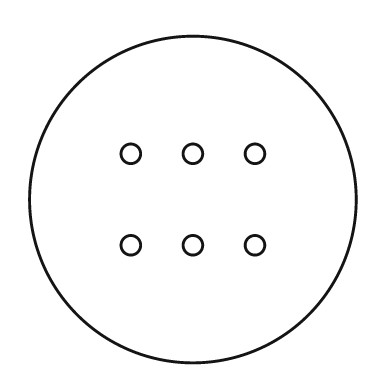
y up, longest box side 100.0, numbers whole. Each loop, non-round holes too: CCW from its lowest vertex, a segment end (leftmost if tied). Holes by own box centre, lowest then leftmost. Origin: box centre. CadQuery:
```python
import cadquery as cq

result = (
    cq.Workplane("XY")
    .moveTo(0.0, 0.0)
    .circle(50.0)
    .moveTo(-19.0, -14.0)
    .circle(3.0)
    .moveTo(0.0, -14.0)
    .circle(3.0)
    .moveTo(19.0, -14.0)
    .circle(3.0)
    .moveTo(-19.0, 14.0)
    .circle(3.0)
    .moveTo(0.0, 14.0)
    .circle(3.0)
    .moveTo(19.0, 14.0)
    .circle(3.0)
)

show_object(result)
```